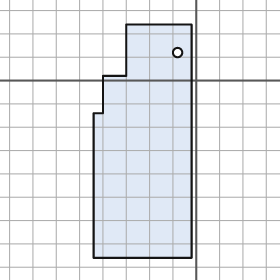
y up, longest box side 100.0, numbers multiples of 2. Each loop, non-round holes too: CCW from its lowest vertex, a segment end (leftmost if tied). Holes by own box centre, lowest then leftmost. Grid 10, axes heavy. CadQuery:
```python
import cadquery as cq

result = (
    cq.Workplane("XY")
    .moveTo(-44.0, -76.0)
    .lineTo(-2.0, -76.0)
    .lineTo(-2.0, 24.0)
    .lineTo(-30.0, 24.0)
    .lineTo(-30.0, 2.0)
    .lineTo(-40.0, 2.0)
    .lineTo(-40.0, -14.0)
    .lineTo(-44.0, -14.0)
    .close()
    .moveTo(-8.0, 12.0)
    .circle(2.0)
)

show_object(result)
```